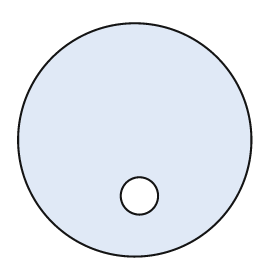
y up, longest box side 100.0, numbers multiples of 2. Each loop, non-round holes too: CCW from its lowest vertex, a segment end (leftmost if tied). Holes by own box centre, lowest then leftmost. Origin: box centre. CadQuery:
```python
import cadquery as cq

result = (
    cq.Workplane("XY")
    .moveTo(0.0, 0.0)
    .circle(50.0)
    .moveTo(2.0, -24.0)
    .circle(8.0)
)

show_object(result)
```